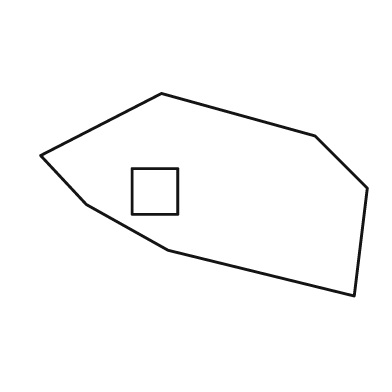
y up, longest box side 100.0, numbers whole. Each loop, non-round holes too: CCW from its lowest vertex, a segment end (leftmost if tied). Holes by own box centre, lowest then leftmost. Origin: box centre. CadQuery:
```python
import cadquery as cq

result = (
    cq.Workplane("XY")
    .moveTo(46.0, -31.0)
    .lineTo(50.0, 2.0)
    .lineTo(34.0, 18.0)
    .lineTo(-13.0, 31.0)
    .lineTo(-50.0, 12.0)
    .lineTo(-36.0, -3.0)
    .lineTo(-11.0, -17.0)
    .close()
    .moveTo(-22.0, -6.0)
    .lineTo(-8.0, -6.0)
    .lineTo(-8.0, 8.0)
    .lineTo(-22.0, 8.0)
    .close()
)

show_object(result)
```